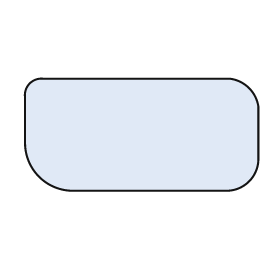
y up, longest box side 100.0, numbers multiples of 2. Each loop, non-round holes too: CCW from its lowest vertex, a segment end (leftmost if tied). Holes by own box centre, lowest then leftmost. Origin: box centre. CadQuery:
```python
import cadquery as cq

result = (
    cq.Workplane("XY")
    .moveTo(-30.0, -24.0)
    .lineTo(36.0, -24.0)
    .threePointArc((46.0, -20.0), (50.0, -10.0))
    .lineTo(50.0, 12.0)
    .threePointArc((46.0, 20.0), (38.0, 24.0))
    .lineTo(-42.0, 24.0)
    .threePointArc((-48.0, 22.0), (-50.0, 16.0))
    .lineTo(-50.0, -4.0)
    .threePointArc((-44.0, -18.0), (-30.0, -24.0))
    .close()
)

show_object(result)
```